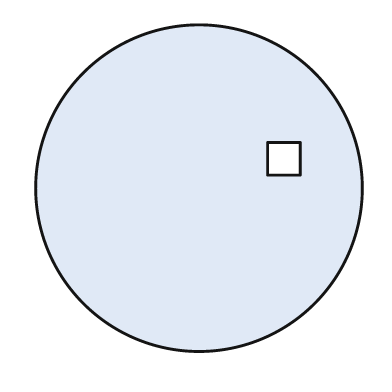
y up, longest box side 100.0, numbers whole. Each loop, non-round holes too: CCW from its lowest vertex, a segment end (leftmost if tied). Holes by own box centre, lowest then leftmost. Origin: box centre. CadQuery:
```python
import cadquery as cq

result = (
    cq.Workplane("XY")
    .moveTo(0.0, 0.0)
    .circle(50.0)
    .moveTo(21.0, 4.0)
    .lineTo(31.0, 4.0)
    .lineTo(31.0, 14.0)
    .lineTo(21.0, 14.0)
    .close()
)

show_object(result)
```